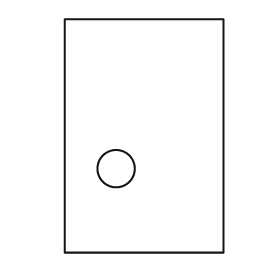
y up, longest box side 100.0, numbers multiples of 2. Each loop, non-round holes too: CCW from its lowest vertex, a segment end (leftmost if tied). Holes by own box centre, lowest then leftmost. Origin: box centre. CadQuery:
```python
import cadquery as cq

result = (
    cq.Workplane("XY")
    .moveTo(-34.0, -50.0)
    .lineTo(34.0, -50.0)
    .lineTo(34.0, 50.0)
    .lineTo(-34.0, 50.0)
    .close()
    .moveTo(-12.0, -14.0)
    .circle(8.0)
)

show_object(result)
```